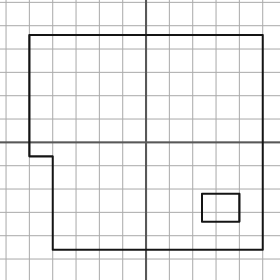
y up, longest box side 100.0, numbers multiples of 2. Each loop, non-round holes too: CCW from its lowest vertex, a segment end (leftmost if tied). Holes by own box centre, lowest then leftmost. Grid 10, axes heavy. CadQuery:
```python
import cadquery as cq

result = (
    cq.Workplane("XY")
    .moveTo(-40.0, -46.0)
    .lineTo(50.0, -46.0)
    .lineTo(50.0, 46.0)
    .lineTo(-50.0, 46.0)
    .lineTo(-50.0, -6.0)
    .lineTo(-40.0, -6.0)
    .close()
    .moveTo(24.0, -34.0)
    .lineTo(40.0, -34.0)
    .lineTo(40.0, -22.0)
    .lineTo(24.0, -22.0)
    .close()
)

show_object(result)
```